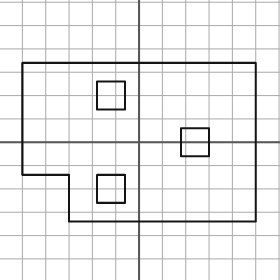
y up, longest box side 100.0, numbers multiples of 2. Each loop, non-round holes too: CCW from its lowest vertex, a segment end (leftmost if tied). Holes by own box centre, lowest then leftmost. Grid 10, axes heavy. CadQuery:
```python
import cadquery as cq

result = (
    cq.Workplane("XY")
    .moveTo(-30.0, -34.0)
    .lineTo(50.0, -34.0)
    .lineTo(50.0, 34.0)
    .lineTo(-50.0, 34.0)
    .lineTo(-50.0, -14.0)
    .lineTo(-30.0, -14.0)
    .close()
    .moveTo(-18.0, -26.0)
    .lineTo(-6.0, -26.0)
    .lineTo(-6.0, -14.0)
    .lineTo(-18.0, -14.0)
    .close()
    .moveTo(18.0, -6.0)
    .lineTo(30.0, -6.0)
    .lineTo(30.0, 6.0)
    .lineTo(18.0, 6.0)
    .close()
    .moveTo(-18.0, 14.0)
    .lineTo(-6.0, 14.0)
    .lineTo(-6.0, 26.0)
    .lineTo(-18.0, 26.0)
    .close()
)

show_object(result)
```